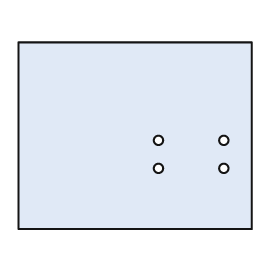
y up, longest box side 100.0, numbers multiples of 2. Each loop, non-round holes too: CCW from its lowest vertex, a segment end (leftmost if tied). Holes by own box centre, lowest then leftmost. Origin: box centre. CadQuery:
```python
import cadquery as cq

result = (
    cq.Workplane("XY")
    .moveTo(-50.0, -40.0)
    .lineTo(50.0, -40.0)
    .lineTo(50.0, 40.0)
    .lineTo(-50.0, 40.0)
    .close()
    .moveTo(10.0, -14.0)
    .circle(2.0)
    .moveTo(38.0, -14.0)
    .circle(2.0)
    .moveTo(10.0, -2.0)
    .circle(2.0)
    .moveTo(38.0, -2.0)
    .circle(2.0)
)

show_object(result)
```